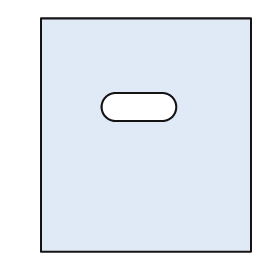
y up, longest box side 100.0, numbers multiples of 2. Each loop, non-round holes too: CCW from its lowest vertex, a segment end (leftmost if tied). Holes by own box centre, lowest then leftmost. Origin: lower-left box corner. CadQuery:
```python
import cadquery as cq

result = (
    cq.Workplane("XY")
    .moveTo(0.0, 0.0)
    .lineTo(90.0, 0.0)
    .lineTo(90.0, 100.0)
    .lineTo(0.0, 100.0)
    .close()
    .moveTo(32.0, 56.0)
    .lineTo(52.0, 56.0)
    .threePointArc((58.0, 62.0), (52.0, 68.0))
    .lineTo(32.0, 68.0)
    .threePointArc((26.0, 62.0), (32.0, 56.0))
    .close()
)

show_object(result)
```